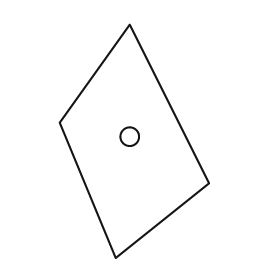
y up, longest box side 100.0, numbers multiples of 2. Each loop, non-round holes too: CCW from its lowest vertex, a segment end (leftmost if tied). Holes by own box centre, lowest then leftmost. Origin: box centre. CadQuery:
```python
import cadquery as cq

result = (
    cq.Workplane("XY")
    .moveTo(-8.0, -50.0)
    .lineTo(32.0, -18.0)
    .lineTo(-2.0, 50.0)
    .lineTo(-32.0, 8.0)
    .close()
    .moveTo(-2.0, 2.0)
    .circle(4.0)
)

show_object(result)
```